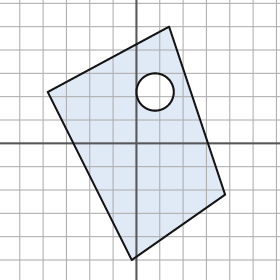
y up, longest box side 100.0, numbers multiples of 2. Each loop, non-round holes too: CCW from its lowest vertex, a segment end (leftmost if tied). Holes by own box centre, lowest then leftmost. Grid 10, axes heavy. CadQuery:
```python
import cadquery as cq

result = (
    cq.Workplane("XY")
    .moveTo(-2.0, -50.0)
    .lineTo(38.0, -22.0)
    .lineTo(14.0, 50.0)
    .lineTo(-38.0, 22.0)
    .close()
    .moveTo(8.0, 22.0)
    .circle(8.0)
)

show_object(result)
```